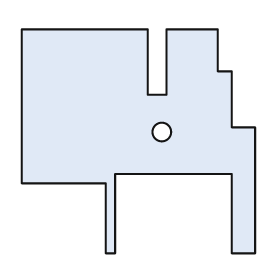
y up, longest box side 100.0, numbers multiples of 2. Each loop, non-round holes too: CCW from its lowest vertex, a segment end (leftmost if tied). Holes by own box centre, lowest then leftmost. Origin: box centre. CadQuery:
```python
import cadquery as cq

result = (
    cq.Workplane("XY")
    .moveTo(-14.0, -48.0)
    .lineTo(-10.0, -48.0)
    .lineTo(-10.0, -14.0)
    .lineTo(40.0, -14.0)
    .lineTo(40.0, -48.0)
    .lineTo(50.0, -48.0)
    .lineTo(50.0, 6.0)
    .lineTo(40.0, 6.0)
    .lineTo(40.0, 30.0)
    .lineTo(34.0, 30.0)
    .lineTo(34.0, 48.0)
    .lineTo(12.0, 48.0)
    .lineTo(12.0, 20.0)
    .lineTo(4.0, 20.0)
    .lineTo(4.0, 48.0)
    .lineTo(-50.0, 48.0)
    .lineTo(-50.0, -18.0)
    .lineTo(-14.0, -18.0)
    .close()
    .moveTo(10.0, 4.0)
    .circle(4.0)
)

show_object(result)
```